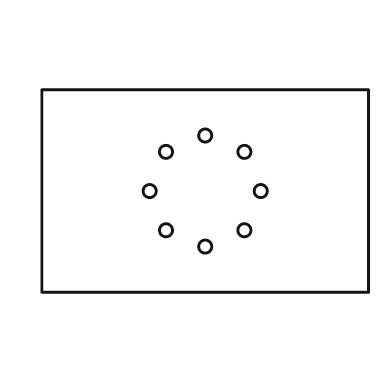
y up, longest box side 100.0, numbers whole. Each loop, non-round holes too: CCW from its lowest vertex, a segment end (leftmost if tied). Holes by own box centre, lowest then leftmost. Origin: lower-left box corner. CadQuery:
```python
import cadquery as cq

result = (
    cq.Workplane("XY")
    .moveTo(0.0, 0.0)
    .lineTo(100.0, 0.0)
    .lineTo(100.0, 62.0)
    .lineTo(0.0, 62.0)
    .close()
    .moveTo(50.0, 14.0)
    .circle(2.0)
    .moveTo(38.0, 19.0)
    .circle(2.0)
    .moveTo(62.0, 19.0)
    .circle(2.0)
    .moveTo(33.0, 31.0)
    .circle(2.0)
    .moveTo(67.0, 31.0)
    .circle(2.0)
    .moveTo(38.0, 43.0)
    .circle(2.0)
    .moveTo(62.0, 43.0)
    .circle(2.0)
    .moveTo(50.0, 48.0)
    .circle(2.0)
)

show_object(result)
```